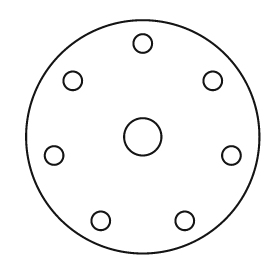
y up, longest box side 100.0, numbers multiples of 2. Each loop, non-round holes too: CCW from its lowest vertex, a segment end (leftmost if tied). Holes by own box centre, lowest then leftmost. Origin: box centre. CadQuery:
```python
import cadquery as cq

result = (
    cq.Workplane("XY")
    .moveTo(0.0, 0.0)
    .circle(50.0)
    .moveTo(-18.0, -36.0)
    .circle(4.0)
    .moveTo(18.0, -36.0)
    .circle(4.0)
    .moveTo(-38.0, -8.0)
    .circle(4.0)
    .moveTo(38.0, -8.0)
    .circle(4.0)
    .moveTo(0.0, 0.0)
    .circle(8.0)
    .moveTo(-30.0, 24.0)
    .circle(4.0)
    .moveTo(30.0, 24.0)
    .circle(4.0)
    .moveTo(0.0, 40.0)
    .circle(4.0)
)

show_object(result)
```